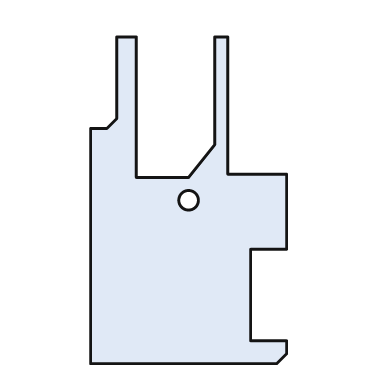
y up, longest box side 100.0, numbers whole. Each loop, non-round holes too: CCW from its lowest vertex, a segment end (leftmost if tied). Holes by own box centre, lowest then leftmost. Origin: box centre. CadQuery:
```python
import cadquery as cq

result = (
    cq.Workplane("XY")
    .moveTo(-30.0, -50.0)
    .lineTo(27.0, -50.0)
    .lineTo(30.0, -47.0)
    .lineTo(30.0, -43.0)
    .lineTo(19.0, -43.0)
    .lineTo(19.0, -15.0)
    .lineTo(30.0, -15.0)
    .lineTo(30.0, 8.0)
    .lineTo(12.0, 8.0)
    .lineTo(12.0, 50.0)
    .lineTo(8.0, 50.0)
    .lineTo(8.0, 17.0)
    .lineTo(0.0, 7.0)
    .lineTo(-16.0, 7.0)
    .lineTo(-16.0, 50.0)
    .lineTo(-22.0, 50.0)
    .lineTo(-22.0, 25.0)
    .lineTo(-25.0, 22.0)
    .lineTo(-30.0, 22.0)
    .close()
    .moveTo(0.0, 0.0)
    .circle(3.0)
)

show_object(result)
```